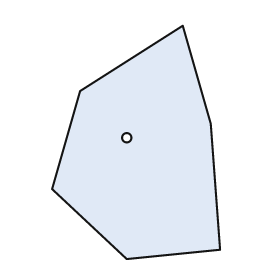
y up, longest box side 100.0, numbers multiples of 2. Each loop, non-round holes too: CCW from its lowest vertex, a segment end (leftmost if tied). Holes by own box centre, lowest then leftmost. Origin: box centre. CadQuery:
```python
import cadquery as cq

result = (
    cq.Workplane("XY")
    .moveTo(-4.0, -50.0)
    .lineTo(36.0, -46.0)
    .lineTo(32.0, 8.0)
    .lineTo(20.0, 50.0)
    .lineTo(-24.0, 22.0)
    .lineTo(-36.0, -20.0)
    .close()
    .moveTo(-4.0, 2.0)
    .circle(2.0)
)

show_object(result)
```